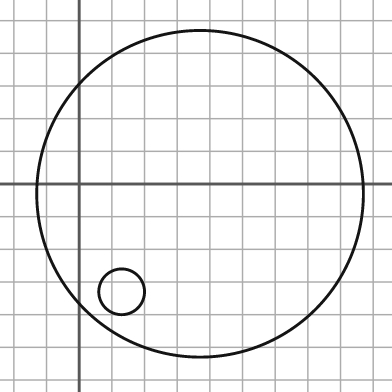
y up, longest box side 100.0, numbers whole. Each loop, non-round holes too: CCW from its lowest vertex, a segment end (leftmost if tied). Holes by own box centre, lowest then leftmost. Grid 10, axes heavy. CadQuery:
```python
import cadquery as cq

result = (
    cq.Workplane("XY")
    .moveTo(37.0, -3.0)
    .circle(50.0)
    .moveTo(13.0, -33.0)
    .circle(7.0)
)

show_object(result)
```